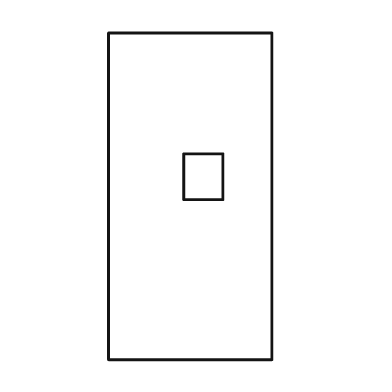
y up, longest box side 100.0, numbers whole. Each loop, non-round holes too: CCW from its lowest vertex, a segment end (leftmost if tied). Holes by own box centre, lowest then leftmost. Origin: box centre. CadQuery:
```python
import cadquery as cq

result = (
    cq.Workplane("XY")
    .moveTo(-25.0, -50.0)
    .lineTo(25.0, -50.0)
    .lineTo(25.0, 50.0)
    .lineTo(-25.0, 50.0)
    .close()
    .moveTo(-2.0, -1.0)
    .lineTo(10.0, -1.0)
    .lineTo(10.0, 13.0)
    .lineTo(-2.0, 13.0)
    .close()
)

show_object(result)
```